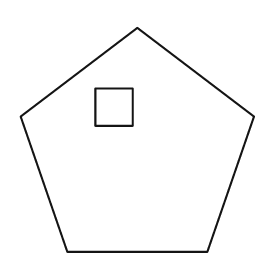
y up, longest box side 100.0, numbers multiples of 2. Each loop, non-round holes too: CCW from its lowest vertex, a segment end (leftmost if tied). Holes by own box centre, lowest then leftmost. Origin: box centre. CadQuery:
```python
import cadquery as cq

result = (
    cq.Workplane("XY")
    .moveTo(-30.0, -48.0)
    .lineTo(30.0, -48.0)
    .lineTo(50.0, 10.0)
    .lineTo(0.0, 48.0)
    .lineTo(-50.0, 10.0)
    .close()
    .moveTo(-18.0, 6.0)
    .lineTo(-2.0, 6.0)
    .lineTo(-2.0, 22.0)
    .lineTo(-18.0, 22.0)
    .close()
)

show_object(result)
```